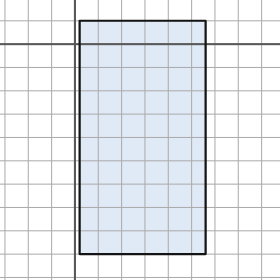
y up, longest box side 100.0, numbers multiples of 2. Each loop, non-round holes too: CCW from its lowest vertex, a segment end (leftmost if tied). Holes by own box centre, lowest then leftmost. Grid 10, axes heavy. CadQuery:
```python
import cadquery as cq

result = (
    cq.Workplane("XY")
    .moveTo(2.0, -90.0)
    .lineTo(56.0, -90.0)
    .lineTo(56.0, 10.0)
    .lineTo(2.0, 10.0)
    .close()
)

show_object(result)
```